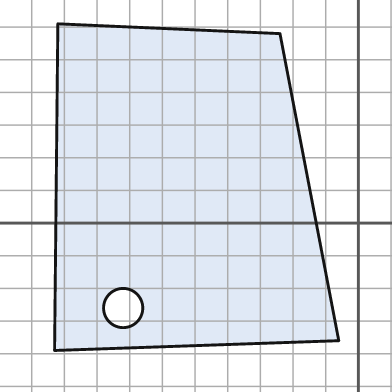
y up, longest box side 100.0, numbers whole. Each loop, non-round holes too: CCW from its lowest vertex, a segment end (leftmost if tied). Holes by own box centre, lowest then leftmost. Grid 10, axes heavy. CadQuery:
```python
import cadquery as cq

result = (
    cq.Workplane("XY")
    .moveTo(-93.0, -39.0)
    .lineTo(-6.0, -36.0)
    .lineTo(-24.0, 58.0)
    .lineTo(-92.0, 61.0)
    .close()
    .moveTo(-72.0, -26.0)
    .circle(6.0)
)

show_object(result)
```